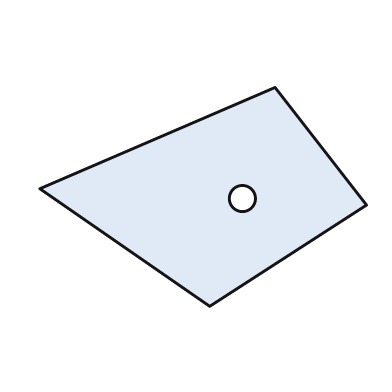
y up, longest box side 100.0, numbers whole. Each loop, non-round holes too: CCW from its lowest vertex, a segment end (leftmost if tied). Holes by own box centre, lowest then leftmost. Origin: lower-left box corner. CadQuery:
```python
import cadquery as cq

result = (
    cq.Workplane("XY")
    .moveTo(52.0, 0.0)
    .lineTo(100.0, 31.0)
    .lineTo(72.0, 67.0)
    .lineTo(0.0, 36.0)
    .close()
    .moveTo(62.0, 33.0)
    .circle(4.0)
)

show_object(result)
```